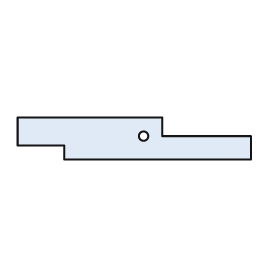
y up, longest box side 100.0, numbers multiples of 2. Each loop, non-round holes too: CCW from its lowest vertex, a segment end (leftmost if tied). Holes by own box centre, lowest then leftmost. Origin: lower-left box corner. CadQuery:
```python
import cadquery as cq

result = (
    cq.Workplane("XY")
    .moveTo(20.0, 0.0)
    .lineTo(100.0, 0.0)
    .lineTo(100.0, 10.0)
    .lineTo(62.0, 10.0)
    .lineTo(62.0, 18.0)
    .lineTo(0.0, 18.0)
    .lineTo(0.0, 6.0)
    .lineTo(20.0, 6.0)
    .close()
    .moveTo(54.0, 10.0)
    .circle(2.0)
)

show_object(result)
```